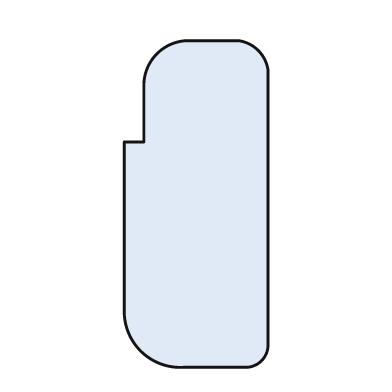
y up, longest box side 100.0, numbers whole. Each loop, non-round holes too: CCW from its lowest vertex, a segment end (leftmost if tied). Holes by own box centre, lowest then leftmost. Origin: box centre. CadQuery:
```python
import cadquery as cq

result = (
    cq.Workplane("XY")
    .moveTo(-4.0, -50.0)
    .lineTo(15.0, -50.0)
    .threePointArc((20.0, -48.0), (22.0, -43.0))
    .lineTo(22.0, 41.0)
    .threePointArc((19.0, 47.0), (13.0, 50.0))
    .lineTo(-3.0, 50.0)
    .threePointArc((-12.0, 46.0), (-16.0, 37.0))
    .lineTo(-16.0, 19.0)
    .lineTo(-22.0, 19.0)
    .lineTo(-22.0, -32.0)
    .threePointArc((-17.0, -45.0), (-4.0, -50.0))
    .close()
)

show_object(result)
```